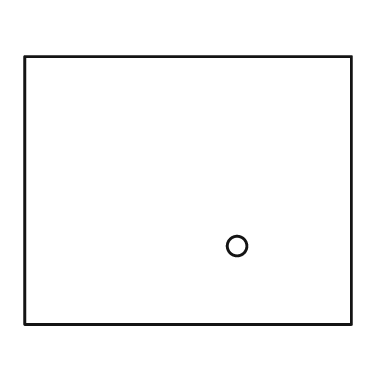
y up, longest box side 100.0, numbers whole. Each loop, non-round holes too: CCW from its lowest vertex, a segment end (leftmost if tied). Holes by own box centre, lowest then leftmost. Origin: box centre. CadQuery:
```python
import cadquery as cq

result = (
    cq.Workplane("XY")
    .moveTo(-50.0, -41.0)
    .lineTo(50.0, -41.0)
    .lineTo(50.0, 41.0)
    .lineTo(-50.0, 41.0)
    .close()
    .moveTo(15.0, -17.0)
    .circle(3.0)
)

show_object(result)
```